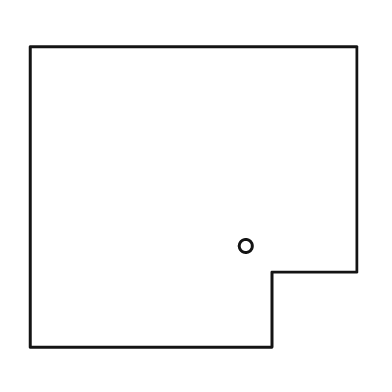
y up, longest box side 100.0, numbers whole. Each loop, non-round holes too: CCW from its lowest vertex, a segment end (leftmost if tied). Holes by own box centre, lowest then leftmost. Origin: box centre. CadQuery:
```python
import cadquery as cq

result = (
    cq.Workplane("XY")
    .moveTo(-50.0, -46.0)
    .lineTo(24.0, -46.0)
    .lineTo(24.0, -23.0)
    .lineTo(50.0, -23.0)
    .lineTo(50.0, 46.0)
    .lineTo(-50.0, 46.0)
    .close()
    .moveTo(16.0, -15.0)
    .circle(2.0)
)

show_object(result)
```